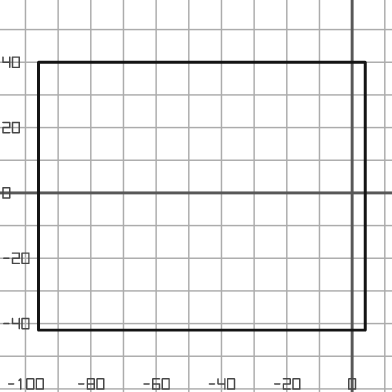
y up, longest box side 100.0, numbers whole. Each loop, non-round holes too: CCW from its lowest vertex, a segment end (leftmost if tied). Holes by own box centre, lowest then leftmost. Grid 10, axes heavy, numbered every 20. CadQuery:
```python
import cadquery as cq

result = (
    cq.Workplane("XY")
    .moveTo(-96.0, -42.0)
    .lineTo(4.0, -42.0)
    .lineTo(4.0, 40.0)
    .lineTo(-96.0, 40.0)
    .close()
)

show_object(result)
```